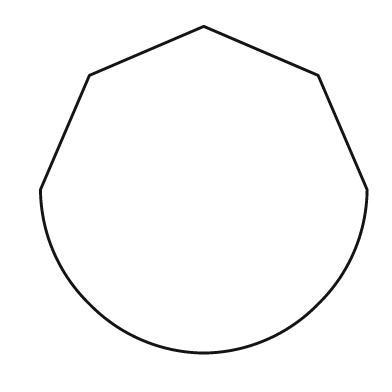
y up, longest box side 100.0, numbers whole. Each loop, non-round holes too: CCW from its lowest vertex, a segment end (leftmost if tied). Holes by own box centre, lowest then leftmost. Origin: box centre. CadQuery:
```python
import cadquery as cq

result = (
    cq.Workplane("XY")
    .moveTo(0.0, -50.0)
    .threePointArc((19.0, -46.0), (35.0, -35.0))
    .threePointArc((46.0, -19.0), (50.0, 0.0))
    .lineTo(35.0, 35.0)
    .lineTo(0.0, 50.0)
    .lineTo(-35.0, 35.0)
    .lineTo(-50.0, 0.0)
    .threePointArc((-46.0, -19.0), (-35.0, -35.0))
    .threePointArc((-19.0, -46.0), (0.0, -50.0))
    .close()
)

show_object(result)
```